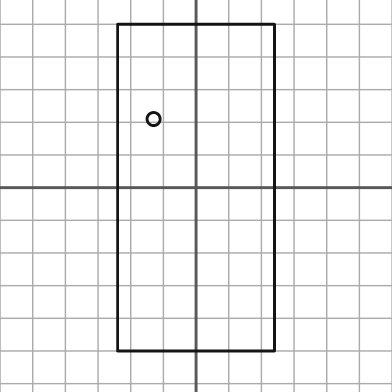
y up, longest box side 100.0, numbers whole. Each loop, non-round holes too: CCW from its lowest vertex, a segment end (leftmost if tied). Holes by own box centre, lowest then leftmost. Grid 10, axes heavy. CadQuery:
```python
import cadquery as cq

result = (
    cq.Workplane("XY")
    .moveTo(-24.0, -50.0)
    .lineTo(24.0, -50.0)
    .lineTo(24.0, 50.0)
    .lineTo(-24.0, 50.0)
    .close()
    .moveTo(-13.0, 21.0)
    .circle(2.0)
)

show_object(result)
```